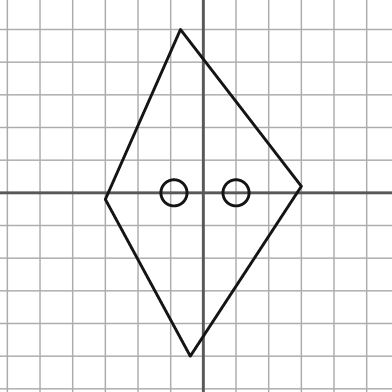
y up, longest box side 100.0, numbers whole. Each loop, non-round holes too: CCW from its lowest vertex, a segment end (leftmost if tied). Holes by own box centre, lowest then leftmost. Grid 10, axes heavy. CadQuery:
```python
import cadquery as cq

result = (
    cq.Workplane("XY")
    .moveTo(-4.0, -50.0)
    .lineTo(30.0, 2.0)
    .lineTo(-7.0, 50.0)
    .lineTo(-30.0, -2.0)
    .close()
    .moveTo(-9.0, 0.0)
    .circle(4.0)
    .moveTo(10.0, 0.0)
    .circle(4.0)
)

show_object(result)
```